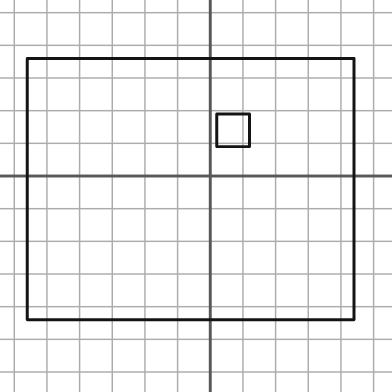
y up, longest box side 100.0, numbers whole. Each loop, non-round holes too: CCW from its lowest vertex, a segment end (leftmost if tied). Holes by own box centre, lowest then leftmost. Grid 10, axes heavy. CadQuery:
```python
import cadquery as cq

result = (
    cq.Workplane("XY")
    .moveTo(-56.0, -44.0)
    .lineTo(44.0, -44.0)
    .lineTo(44.0, 36.0)
    .lineTo(-56.0, 36.0)
    .close()
    .moveTo(2.0, 9.0)
    .lineTo(12.0, 9.0)
    .lineTo(12.0, 19.0)
    .lineTo(2.0, 19.0)
    .close()
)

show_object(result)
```